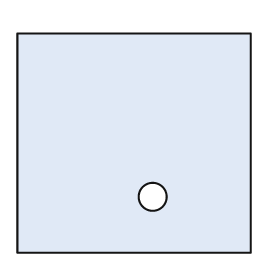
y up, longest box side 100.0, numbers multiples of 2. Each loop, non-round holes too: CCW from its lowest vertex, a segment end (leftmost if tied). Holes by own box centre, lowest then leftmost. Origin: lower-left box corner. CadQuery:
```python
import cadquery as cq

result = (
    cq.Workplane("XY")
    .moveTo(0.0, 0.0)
    .lineTo(100.0, 0.0)
    .lineTo(100.0, 94.0)
    .lineTo(0.0, 94.0)
    .close()
    .moveTo(58.0, 24.0)
    .circle(6.0)
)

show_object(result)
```